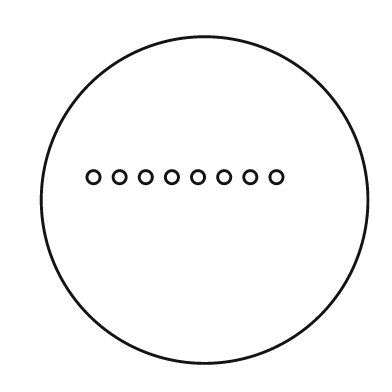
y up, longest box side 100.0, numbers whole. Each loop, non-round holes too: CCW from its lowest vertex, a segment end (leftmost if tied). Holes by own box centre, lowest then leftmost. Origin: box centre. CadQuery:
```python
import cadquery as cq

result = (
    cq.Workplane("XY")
    .moveTo(0.0, 0.0)
    .circle(50.0)
    .moveTo(-34.0, 7.0)
    .circle(2.0)
    .moveTo(-26.0, 7.0)
    .circle(2.0)
    .moveTo(-18.0, 7.0)
    .circle(2.0)
    .moveTo(-10.0, 7.0)
    .circle(2.0)
    .moveTo(-2.0, 7.0)
    .circle(2.0)
    .moveTo(6.0, 7.0)
    .circle(2.0)
    .moveTo(14.0, 7.0)
    .circle(2.0)
    .moveTo(22.0, 7.0)
    .circle(2.0)
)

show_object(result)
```